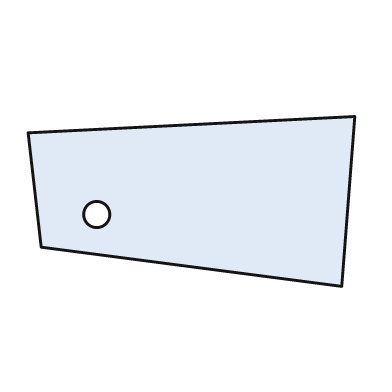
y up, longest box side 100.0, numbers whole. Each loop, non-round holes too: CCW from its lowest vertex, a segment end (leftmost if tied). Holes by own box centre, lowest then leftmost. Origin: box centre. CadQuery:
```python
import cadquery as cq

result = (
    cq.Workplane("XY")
    .moveTo(46.0, -26.0)
    .lineTo(50.0, 26.0)
    .lineTo(-50.0, 21.0)
    .lineTo(-46.0, -14.0)
    .close()
    .moveTo(-29.0, -4.0)
    .circle(4.0)
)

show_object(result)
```